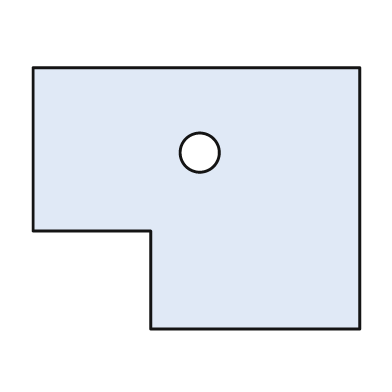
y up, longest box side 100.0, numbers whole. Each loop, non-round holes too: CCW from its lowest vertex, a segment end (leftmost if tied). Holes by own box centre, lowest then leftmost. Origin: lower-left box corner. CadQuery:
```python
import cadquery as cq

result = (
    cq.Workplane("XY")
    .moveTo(36.0, 0.0)
    .lineTo(100.0, 0.0)
    .lineTo(100.0, 80.0)
    .lineTo(0.0, 80.0)
    .lineTo(0.0, 30.0)
    .lineTo(36.0, 30.0)
    .close()
    .moveTo(51.0, 54.0)
    .circle(6.0)
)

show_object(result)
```